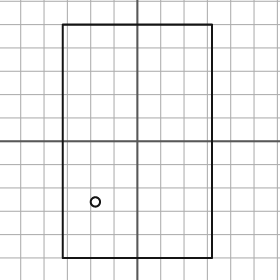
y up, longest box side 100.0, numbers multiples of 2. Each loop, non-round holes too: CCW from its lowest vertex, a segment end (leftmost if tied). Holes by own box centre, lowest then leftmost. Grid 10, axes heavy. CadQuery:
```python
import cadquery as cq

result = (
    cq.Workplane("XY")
    .moveTo(-32.0, -50.0)
    .lineTo(32.0, -50.0)
    .lineTo(32.0, 50.0)
    .lineTo(-32.0, 50.0)
    .close()
    .moveTo(-18.0, -26.0)
    .circle(2.0)
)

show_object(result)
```